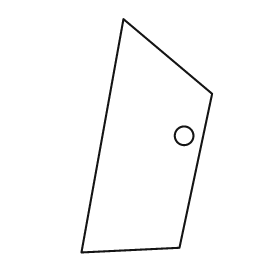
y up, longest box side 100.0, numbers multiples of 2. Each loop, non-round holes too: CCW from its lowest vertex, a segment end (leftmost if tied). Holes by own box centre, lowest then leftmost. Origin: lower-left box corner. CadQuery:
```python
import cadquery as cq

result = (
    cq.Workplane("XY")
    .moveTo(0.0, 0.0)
    .lineTo(42.0, 2.0)
    .lineTo(56.0, 68.0)
    .lineTo(18.0, 100.0)
    .close()
    .moveTo(44.0, 50.0)
    .circle(4.0)
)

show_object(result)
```